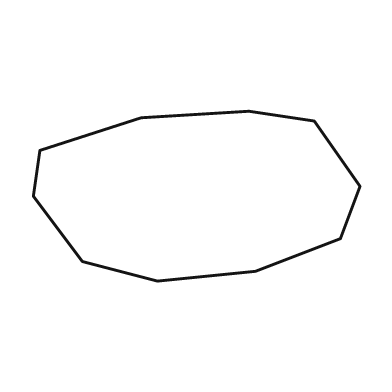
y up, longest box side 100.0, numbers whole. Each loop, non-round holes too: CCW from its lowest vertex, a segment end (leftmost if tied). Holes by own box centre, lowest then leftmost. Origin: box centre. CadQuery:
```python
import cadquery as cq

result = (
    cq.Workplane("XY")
    .moveTo(-12.0, -26.0)
    .lineTo(18.0, -23.0)
    .lineTo(44.0, -13.0)
    .lineTo(50.0, 3.0)
    .lineTo(36.0, 23.0)
    .lineTo(16.0, 26.0)
    .lineTo(-17.0, 24.0)
    .lineTo(-48.0, 14.0)
    .lineTo(-50.0, 0.0)
    .lineTo(-35.0, -20.0)
    .close()
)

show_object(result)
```